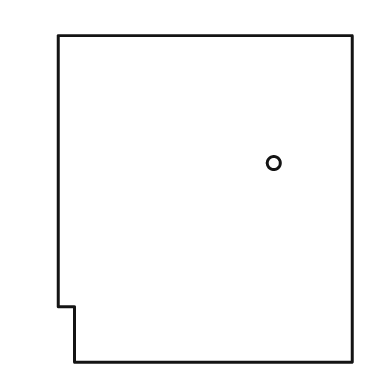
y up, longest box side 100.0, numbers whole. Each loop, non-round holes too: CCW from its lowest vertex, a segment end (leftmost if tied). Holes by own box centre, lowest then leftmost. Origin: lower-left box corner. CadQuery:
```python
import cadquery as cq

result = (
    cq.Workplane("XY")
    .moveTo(5.0, 0.0)
    .lineTo(90.0, 0.0)
    .lineTo(90.0, 100.0)
    .lineTo(0.0, 100.0)
    .lineTo(0.0, 17.0)
    .lineTo(5.0, 17.0)
    .close()
    .moveTo(66.0, 61.0)
    .circle(2.0)
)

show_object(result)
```